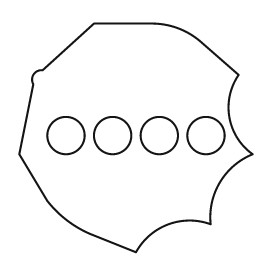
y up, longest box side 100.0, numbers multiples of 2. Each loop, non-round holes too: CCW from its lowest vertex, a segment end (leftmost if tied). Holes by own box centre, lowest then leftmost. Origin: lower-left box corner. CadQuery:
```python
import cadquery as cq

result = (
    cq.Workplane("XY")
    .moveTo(50.0, 0.0)
    .threePointArc((64.0, 12.0), (82.0, 12.0))
    .threePointArc((86.0, 30.0), (100.0, 42.0))
    .threePointArc((90.0, 58.0), (94.0, 76.0))
    .lineTo(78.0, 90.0)
    .threePointArc((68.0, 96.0), (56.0, 98.0))
    .lineTo(32.0, 98.0)
    .lineTo(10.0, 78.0)
    .threePointArc((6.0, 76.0), (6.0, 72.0))
    .lineTo(0.0, 42.0)
    .lineTo(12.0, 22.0)
    .threePointArc((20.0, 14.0), (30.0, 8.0))
    .close()
    .moveTo(20.0, 50.0)
    .circle(8.0)
    .moveTo(40.0, 50.0)
    .circle(8.0)
    .moveTo(60.0, 50.0)
    .circle(8.0)
    .moveTo(80.0, 50.0)
    .circle(8.0)
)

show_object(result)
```